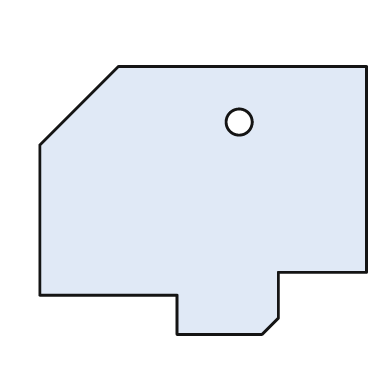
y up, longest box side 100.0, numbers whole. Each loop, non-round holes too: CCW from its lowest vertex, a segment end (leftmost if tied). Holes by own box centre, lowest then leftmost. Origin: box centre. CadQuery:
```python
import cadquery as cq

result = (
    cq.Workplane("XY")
    .moveTo(-8.0, -41.0)
    .lineTo(18.0, -41.0)
    .lineTo(23.0, -36.0)
    .lineTo(23.0, -22.0)
    .lineTo(50.0, -22.0)
    .lineTo(50.0, 41.0)
    .lineTo(-26.0, 41.0)
    .lineTo(-50.0, 17.0)
    .lineTo(-50.0, -29.0)
    .lineTo(-8.0, -29.0)
    .close()
    .moveTo(11.0, 24.0)
    .circle(4.0)
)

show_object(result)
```